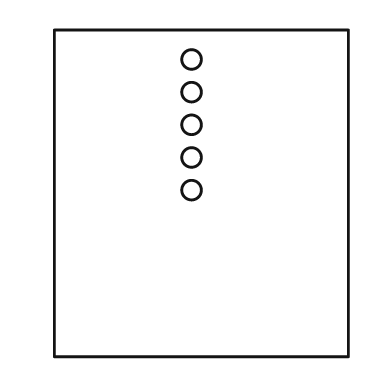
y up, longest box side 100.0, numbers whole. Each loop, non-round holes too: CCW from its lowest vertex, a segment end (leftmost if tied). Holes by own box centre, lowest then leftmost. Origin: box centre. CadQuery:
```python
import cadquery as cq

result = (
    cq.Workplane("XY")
    .moveTo(-45.0, -50.0)
    .lineTo(45.0, -50.0)
    .lineTo(45.0, 50.0)
    .lineTo(-45.0, 50.0)
    .close()
    .moveTo(-3.0, 1.0)
    .circle(3.0)
    .moveTo(-3.0, 11.0)
    .circle(3.0)
    .moveTo(-3.0, 21.0)
    .circle(3.0)
    .moveTo(-3.0, 31.0)
    .circle(3.0)
    .moveTo(-3.0, 41.0)
    .circle(3.0)
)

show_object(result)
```